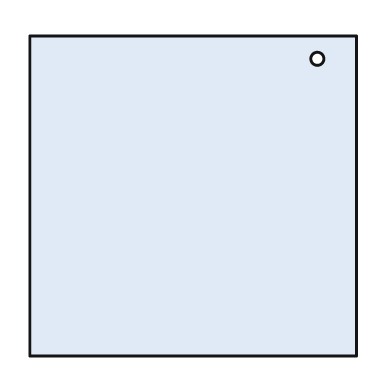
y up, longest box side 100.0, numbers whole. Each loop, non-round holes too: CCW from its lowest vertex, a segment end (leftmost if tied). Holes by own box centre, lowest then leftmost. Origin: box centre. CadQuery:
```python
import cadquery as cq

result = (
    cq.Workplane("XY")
    .moveTo(-50.0, -49.0)
    .lineTo(50.0, -49.0)
    .lineTo(50.0, 49.0)
    .lineTo(-50.0, 49.0)
    .close()
    .moveTo(38.0, 42.0)
    .circle(2.0)
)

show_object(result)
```